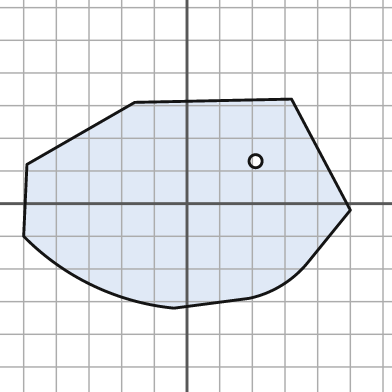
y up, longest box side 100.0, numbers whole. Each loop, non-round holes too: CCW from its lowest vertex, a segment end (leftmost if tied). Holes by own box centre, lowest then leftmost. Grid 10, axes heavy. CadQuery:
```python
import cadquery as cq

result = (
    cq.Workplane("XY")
    .moveTo(-4.0, -32.0)
    .lineTo(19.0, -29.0)
    .threePointArc((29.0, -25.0), (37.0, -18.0))
    .lineTo(50.0, -2.0)
    .lineTo(32.0, 32.0)
    .lineTo(-16.0, 31.0)
    .lineTo(-49.0, 12.0)
    .lineTo(-50.0, -10.0)
    .threePointArc((-29.0, -25.0), (-4.0, -32.0))
    .close()
    .moveTo(21.0, 13.0)
    .circle(2.0)
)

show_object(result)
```